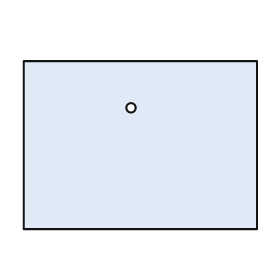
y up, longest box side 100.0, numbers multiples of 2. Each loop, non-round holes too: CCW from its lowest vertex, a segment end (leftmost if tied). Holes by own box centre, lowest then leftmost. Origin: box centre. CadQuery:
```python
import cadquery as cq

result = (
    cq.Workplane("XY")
    .moveTo(-50.0, -36.0)
    .lineTo(50.0, -36.0)
    .lineTo(50.0, 36.0)
    .lineTo(-50.0, 36.0)
    .close()
    .moveTo(-4.0, 16.0)
    .circle(2.0)
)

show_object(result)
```